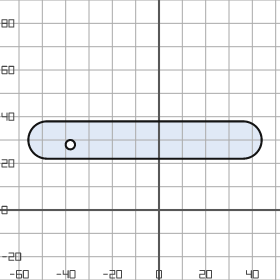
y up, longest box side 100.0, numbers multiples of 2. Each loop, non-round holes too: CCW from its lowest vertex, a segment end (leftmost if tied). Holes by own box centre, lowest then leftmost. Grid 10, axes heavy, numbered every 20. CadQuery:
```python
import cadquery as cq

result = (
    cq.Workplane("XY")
    .moveTo(-48.0, 22.0)
    .lineTo(36.0, 22.0)
    .threePointArc((44.0, 30.0), (36.0, 38.0))
    .lineTo(-48.0, 38.0)
    .threePointArc((-56.0, 30.0), (-48.0, 22.0))
    .close()
    .moveTo(-38.0, 28.0)
    .circle(2.0)
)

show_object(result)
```